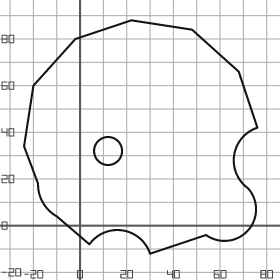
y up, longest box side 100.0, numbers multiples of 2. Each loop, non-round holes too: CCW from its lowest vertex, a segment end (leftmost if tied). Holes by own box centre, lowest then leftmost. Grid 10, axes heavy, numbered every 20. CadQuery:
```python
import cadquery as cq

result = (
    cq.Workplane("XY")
    .moveTo(30.0, -12.0)
    .lineTo(54.0, -4.0)
    .threePointArc((72.0, -2.0), (72.0, 16.0))
    .threePointArc((66.0, 30.0), (76.0, 42.0))
    .lineTo(68.0, 66.0)
    .lineTo(48.0, 84.0)
    .lineTo(22.0, 88.0)
    .lineTo(-2.0, 80.0)
    .lineTo(-20.0, 60.0)
    .lineTo(-24.0, 34.0)
    .lineTo(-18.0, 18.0)
    .threePointArc((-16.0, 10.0), (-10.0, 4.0))
    .lineTo(4.0, -8.0)
    .threePointArc((18.0, -2.0), (30.0, -12.0))
    .close()
    .moveTo(12.0, 32.0)
    .circle(6.0)
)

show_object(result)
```